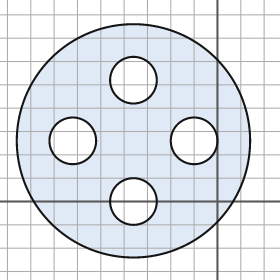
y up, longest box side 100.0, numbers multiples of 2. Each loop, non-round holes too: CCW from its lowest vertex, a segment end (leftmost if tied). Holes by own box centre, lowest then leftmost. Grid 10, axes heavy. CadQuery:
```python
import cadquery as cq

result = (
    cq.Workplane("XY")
    .moveTo(-36.0, 26.0)
    .circle(50.0)
    .moveTo(-36.0, 0.0)
    .circle(10.0)
    .moveTo(-62.0, 26.0)
    .circle(10.0)
    .moveTo(-10.0, 26.0)
    .circle(10.0)
    .moveTo(-36.0, 52.0)
    .circle(10.0)
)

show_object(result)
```